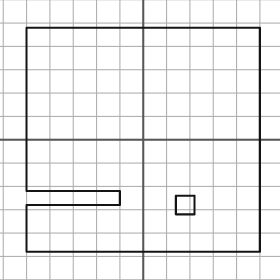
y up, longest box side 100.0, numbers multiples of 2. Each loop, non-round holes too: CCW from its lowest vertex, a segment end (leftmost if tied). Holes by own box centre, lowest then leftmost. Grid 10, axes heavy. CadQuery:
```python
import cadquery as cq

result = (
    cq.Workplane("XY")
    .moveTo(-50.0, -48.0)
    .lineTo(50.0, -48.0)
    .lineTo(50.0, 48.0)
    .lineTo(-50.0, 48.0)
    .lineTo(-50.0, -22.0)
    .lineTo(-10.0, -22.0)
    .lineTo(-10.0, -28.0)
    .lineTo(-50.0, -28.0)
    .close()
    .moveTo(14.0, -32.0)
    .lineTo(22.0, -32.0)
    .lineTo(22.0, -24.0)
    .lineTo(14.0, -24.0)
    .close()
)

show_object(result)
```